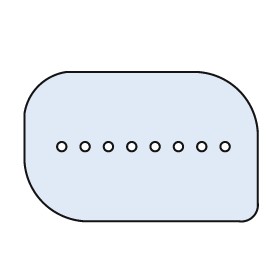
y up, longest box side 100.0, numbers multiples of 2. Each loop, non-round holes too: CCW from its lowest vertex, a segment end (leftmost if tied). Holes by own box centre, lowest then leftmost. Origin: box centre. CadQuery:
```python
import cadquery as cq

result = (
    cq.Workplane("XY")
    .moveTo(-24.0, -32.0)
    .lineTo(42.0, -32.0)
    .threePointArc((48.0, -30.0), (50.0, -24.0))
    .lineTo(50.0, 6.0)
    .threePointArc((42.0, 24.0), (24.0, 32.0))
    .lineTo(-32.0, 32.0)
    .threePointArc((-44.0, 26.0), (-50.0, 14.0))
    .lineTo(-50.0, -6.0)
    .threePointArc((-42.0, -24.0), (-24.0, -32.0))
    .close()
    .moveTo(-34.0, 0.0)
    .circle(2.0)
    .moveTo(-24.0, 0.0)
    .circle(2.0)
    .moveTo(-14.0, 0.0)
    .circle(2.0)
    .moveTo(-4.0, 0.0)
    .circle(2.0)
    .moveTo(6.0, 0.0)
    .circle(2.0)
    .moveTo(16.0, 0.0)
    .circle(2.0)
    .moveTo(26.0, 0.0)
    .circle(2.0)
    .moveTo(36.0, 0.0)
    .circle(2.0)
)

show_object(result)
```